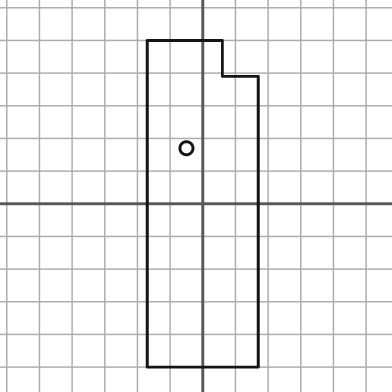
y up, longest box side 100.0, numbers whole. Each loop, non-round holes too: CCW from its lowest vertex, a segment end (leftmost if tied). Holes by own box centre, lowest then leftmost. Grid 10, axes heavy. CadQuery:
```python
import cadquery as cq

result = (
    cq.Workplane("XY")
    .moveTo(-17.0, -50.0)
    .lineTo(17.0, -50.0)
    .lineTo(17.0, 39.0)
    .lineTo(6.0, 39.0)
    .lineTo(6.0, 50.0)
    .lineTo(-17.0, 50.0)
    .close()
    .moveTo(-5.0, 17.0)
    .circle(2.0)
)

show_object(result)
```